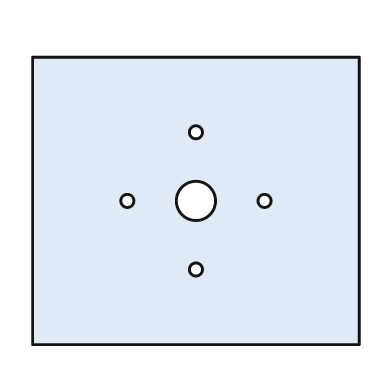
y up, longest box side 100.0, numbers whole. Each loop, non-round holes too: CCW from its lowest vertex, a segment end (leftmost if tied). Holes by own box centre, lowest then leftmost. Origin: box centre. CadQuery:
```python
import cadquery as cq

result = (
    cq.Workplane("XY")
    .moveTo(-50.0, -44.0)
    .lineTo(50.0, -44.0)
    .lineTo(50.0, 44.0)
    .lineTo(-50.0, 44.0)
    .close()
    .moveTo(0.0, -21.0)
    .circle(2.0)
    .moveTo(-21.0, 0.0)
    .circle(2.0)
    .moveTo(0.0, 0.0)
    .circle(6.0)
    .moveTo(21.0, 0.0)
    .circle(2.0)
    .moveTo(0.0, 21.0)
    .circle(2.0)
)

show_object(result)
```